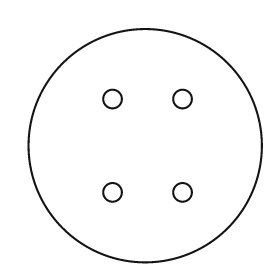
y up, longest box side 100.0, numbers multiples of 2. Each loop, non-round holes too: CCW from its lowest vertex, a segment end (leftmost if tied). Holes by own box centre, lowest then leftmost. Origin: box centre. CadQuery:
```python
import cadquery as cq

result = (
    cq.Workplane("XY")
    .moveTo(0.0, 0.0)
    .circle(50.0)
    .moveTo(-14.0, -20.0)
    .circle(4.0)
    .moveTo(16.0, -20.0)
    .circle(4.0)
    .moveTo(-14.0, 20.0)
    .circle(4.0)
    .moveTo(16.0, 20.0)
    .circle(4.0)
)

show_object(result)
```